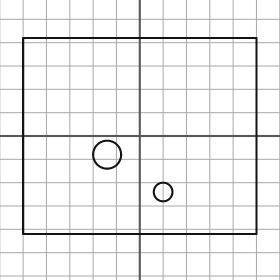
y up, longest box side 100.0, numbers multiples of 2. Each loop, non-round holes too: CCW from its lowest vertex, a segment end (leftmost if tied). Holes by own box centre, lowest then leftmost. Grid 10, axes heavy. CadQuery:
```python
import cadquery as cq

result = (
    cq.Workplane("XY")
    .moveTo(-50.0, -42.0)
    .lineTo(50.0, -42.0)
    .lineTo(50.0, 42.0)
    .lineTo(-50.0, 42.0)
    .close()
    .moveTo(10.0, -24.0)
    .circle(4.0)
    .moveTo(-14.0, -8.0)
    .circle(6.0)
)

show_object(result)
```